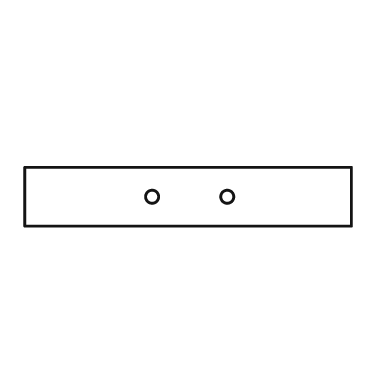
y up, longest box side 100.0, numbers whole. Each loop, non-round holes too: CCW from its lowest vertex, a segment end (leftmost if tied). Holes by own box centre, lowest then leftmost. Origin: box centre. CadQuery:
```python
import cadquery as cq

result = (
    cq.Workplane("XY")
    .moveTo(-50.0, -9.0)
    .lineTo(50.0, -9.0)
    .lineTo(50.0, 9.0)
    .lineTo(-50.0, 9.0)
    .close()
    .moveTo(-11.0, 0.0)
    .circle(2.0)
    .moveTo(12.0, 0.0)
    .circle(2.0)
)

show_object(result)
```